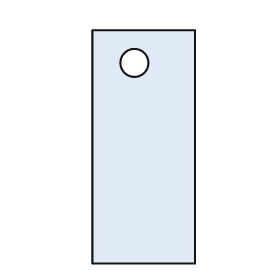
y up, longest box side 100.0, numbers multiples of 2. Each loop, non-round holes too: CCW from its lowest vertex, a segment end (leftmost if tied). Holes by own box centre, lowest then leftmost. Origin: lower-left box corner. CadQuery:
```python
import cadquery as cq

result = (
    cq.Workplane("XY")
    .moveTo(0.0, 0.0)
    .lineTo(44.0, 0.0)
    .lineTo(44.0, 100.0)
    .lineTo(0.0, 100.0)
    .close()
    .moveTo(18.0, 86.0)
    .circle(6.0)
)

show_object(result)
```